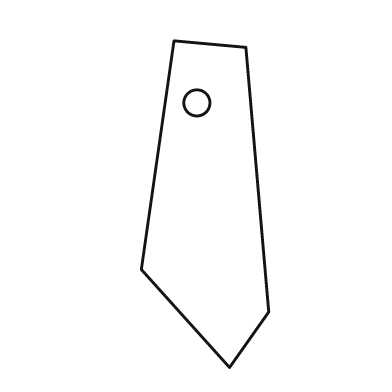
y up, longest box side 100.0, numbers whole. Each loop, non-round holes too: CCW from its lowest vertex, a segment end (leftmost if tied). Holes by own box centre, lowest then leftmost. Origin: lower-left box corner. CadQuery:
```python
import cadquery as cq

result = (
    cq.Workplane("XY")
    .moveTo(27.0, 0.0)
    .lineTo(39.0, 17.0)
    .lineTo(32.0, 98.0)
    .lineTo(10.0, 100.0)
    .lineTo(0.0, 30.0)
    .close()
    .moveTo(17.0, 81.0)
    .circle(4.0)
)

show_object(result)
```